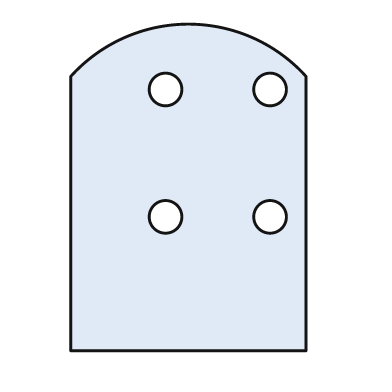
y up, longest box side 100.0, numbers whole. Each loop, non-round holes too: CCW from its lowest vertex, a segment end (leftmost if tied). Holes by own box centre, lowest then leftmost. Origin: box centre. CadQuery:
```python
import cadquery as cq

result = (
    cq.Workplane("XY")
    .moveTo(-36.0, -50.0)
    .lineTo(36.0, -50.0)
    .lineTo(36.0, 34.0)
    .threePointArc((0.0, 50.0), (-36.0, 34.0))
    .close()
    .moveTo(-7.0, -9.0)
    .circle(5.0)
    .moveTo(25.0, -9.0)
    .circle(5.0)
    .moveTo(-7.0, 30.0)
    .circle(5.0)
    .moveTo(25.0, 30.0)
    .circle(5.0)
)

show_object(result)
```